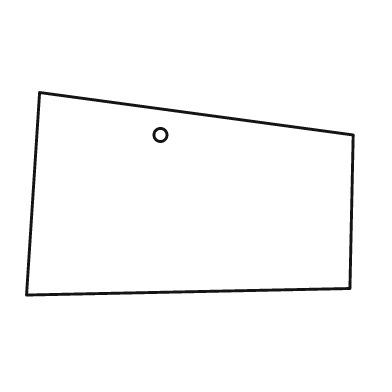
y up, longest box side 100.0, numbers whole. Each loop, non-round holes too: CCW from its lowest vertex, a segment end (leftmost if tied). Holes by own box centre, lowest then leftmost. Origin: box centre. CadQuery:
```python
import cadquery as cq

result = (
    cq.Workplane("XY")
    .moveTo(-50.0, -31.0)
    .lineTo(49.0, -29.0)
    .lineTo(50.0, 18.0)
    .lineTo(-46.0, 31.0)
    .close()
    .moveTo(-9.0, 18.0)
    .circle(2.0)
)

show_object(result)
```